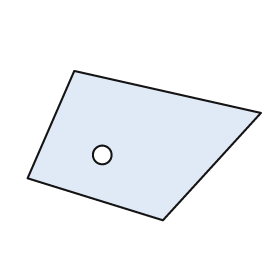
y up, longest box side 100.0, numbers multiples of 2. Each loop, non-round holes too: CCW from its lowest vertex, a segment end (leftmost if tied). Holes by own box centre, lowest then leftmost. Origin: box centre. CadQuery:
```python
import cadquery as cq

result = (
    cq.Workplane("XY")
    .moveTo(8.0, -32.0)
    .lineTo(50.0, 14.0)
    .lineTo(-30.0, 32.0)
    .lineTo(-50.0, -14.0)
    .close()
    .moveTo(-18.0, -4.0)
    .circle(4.0)
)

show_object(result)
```